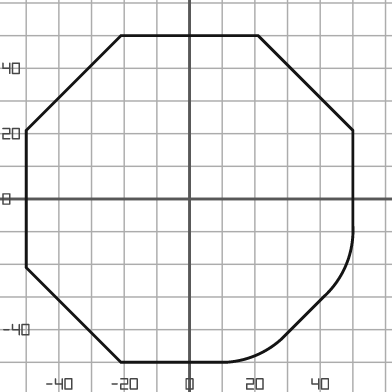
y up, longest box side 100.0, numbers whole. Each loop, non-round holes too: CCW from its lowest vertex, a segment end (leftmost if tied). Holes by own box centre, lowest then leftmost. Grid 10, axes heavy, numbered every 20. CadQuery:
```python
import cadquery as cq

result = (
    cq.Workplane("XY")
    .moveTo(-21.0, -50.0)
    .lineTo(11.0, -50.0)
    .threePointArc((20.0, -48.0), (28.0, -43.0))
    .lineTo(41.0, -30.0)
    .threePointArc((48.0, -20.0), (50.0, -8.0))
    .lineTo(50.0, 21.0)
    .lineTo(21.0, 50.0)
    .lineTo(-21.0, 50.0)
    .lineTo(-50.0, 21.0)
    .lineTo(-50.0, -21.0)
    .close()
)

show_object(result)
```